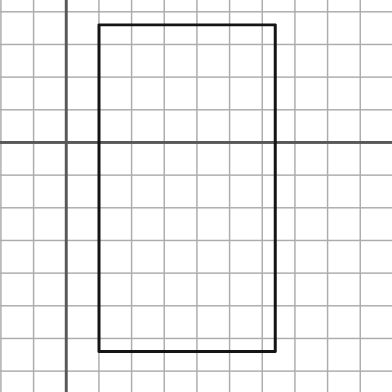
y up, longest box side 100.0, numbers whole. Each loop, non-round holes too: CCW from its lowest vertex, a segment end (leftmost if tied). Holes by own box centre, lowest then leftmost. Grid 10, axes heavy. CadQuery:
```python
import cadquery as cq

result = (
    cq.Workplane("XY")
    .moveTo(10.0, -64.0)
    .lineTo(64.0, -64.0)
    .lineTo(64.0, 36.0)
    .lineTo(10.0, 36.0)
    .close()
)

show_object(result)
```